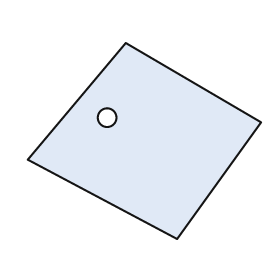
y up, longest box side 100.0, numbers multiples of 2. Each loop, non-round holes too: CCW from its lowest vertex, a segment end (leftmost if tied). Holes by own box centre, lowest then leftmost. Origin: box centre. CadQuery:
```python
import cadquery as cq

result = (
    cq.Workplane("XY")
    .moveTo(14.0, -42.0)
    .lineTo(50.0, 8.0)
    .lineTo(-8.0, 42.0)
    .lineTo(-50.0, -8.0)
    .close()
    .moveTo(-16.0, 10.0)
    .circle(4.0)
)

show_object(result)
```